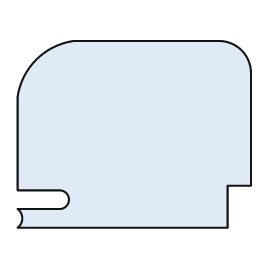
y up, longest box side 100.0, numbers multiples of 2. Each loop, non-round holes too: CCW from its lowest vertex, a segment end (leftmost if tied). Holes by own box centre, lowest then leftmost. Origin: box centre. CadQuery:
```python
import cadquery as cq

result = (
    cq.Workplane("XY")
    .moveTo(-50.0, -40.0)
    .lineTo(40.0, -40.0)
    .lineTo(40.0, -22.0)
    .lineTo(50.0, -22.0)
    .lineTo(50.0, 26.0)
    .threePointArc((46.0, 36.0), (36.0, 40.0))
    .lineTo(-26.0, 40.0)
    .threePointArc((-42.0, 32.0), (-50.0, 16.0))
    .lineTo(-50.0, -24.0)
    .lineTo(-32.0, -24.0)
    .threePointArc((-28.0, -28.0), (-32.0, -32.0))
    .lineTo(-50.0, -32.0)
    .threePointArc((-48.0, -36.0), (-50.0, -40.0))
    .close()
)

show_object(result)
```